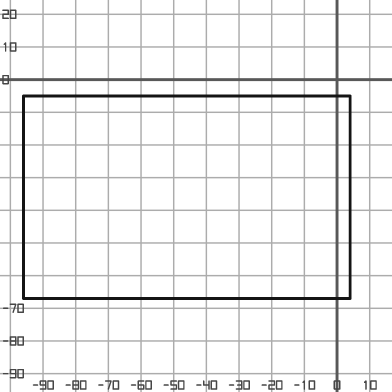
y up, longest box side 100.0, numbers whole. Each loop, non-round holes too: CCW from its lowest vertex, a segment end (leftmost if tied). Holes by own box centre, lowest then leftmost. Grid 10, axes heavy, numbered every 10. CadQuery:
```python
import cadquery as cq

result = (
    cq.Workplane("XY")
    .moveTo(-96.0, -67.0)
    .lineTo(4.0, -67.0)
    .lineTo(4.0, -5.0)
    .lineTo(-96.0, -5.0)
    .close()
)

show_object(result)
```